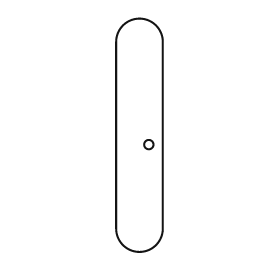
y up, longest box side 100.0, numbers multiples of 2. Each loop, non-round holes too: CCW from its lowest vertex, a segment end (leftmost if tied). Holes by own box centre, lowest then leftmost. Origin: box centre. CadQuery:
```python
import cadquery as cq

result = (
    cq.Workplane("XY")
    .moveTo(-10.0, -40.0)
    .threePointArc((0.0, -50.0), (10.0, -40.0))
    .lineTo(10.0, 40.0)
    .threePointArc((0.0, 50.0), (-10.0, 40.0))
    .close()
    .moveTo(4.0, -4.0)
    .circle(2.0)
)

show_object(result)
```